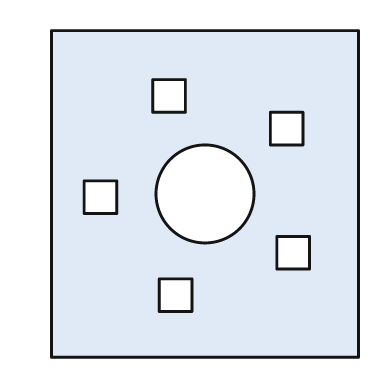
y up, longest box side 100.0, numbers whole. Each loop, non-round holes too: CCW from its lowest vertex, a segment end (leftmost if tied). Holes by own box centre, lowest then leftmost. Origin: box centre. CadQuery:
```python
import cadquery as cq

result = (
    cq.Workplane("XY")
    .moveTo(-47.0, -50.0)
    .lineTo(47.0, -50.0)
    .lineTo(47.0, 50.0)
    .lineTo(-47.0, 50.0)
    .close()
    .moveTo(-14.0, -36.0)
    .lineTo(-4.0, -36.0)
    .lineTo(-4.0, -26.0)
    .lineTo(-14.0, -26.0)
    .close()
    .moveTo(22.0, -23.0)
    .lineTo(32.0, -23.0)
    .lineTo(32.0, -13.0)
    .lineTo(22.0, -13.0)
    .close()
    .moveTo(-37.0, -6.0)
    .lineTo(-27.0, -6.0)
    .lineTo(-27.0, 4.0)
    .lineTo(-37.0, 4.0)
    .close()
    .moveTo(0.0, 0.0)
    .circle(15.0)
    .moveTo(20.0, 15.0)
    .lineTo(30.0, 15.0)
    .lineTo(30.0, 25.0)
    .lineTo(20.0, 25.0)
    .close()
    .moveTo(-16.0, 25.0)
    .lineTo(-6.0, 25.0)
    .lineTo(-6.0, 35.0)
    .lineTo(-16.0, 35.0)
    .close()
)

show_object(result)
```